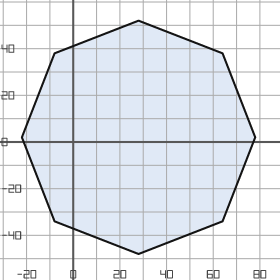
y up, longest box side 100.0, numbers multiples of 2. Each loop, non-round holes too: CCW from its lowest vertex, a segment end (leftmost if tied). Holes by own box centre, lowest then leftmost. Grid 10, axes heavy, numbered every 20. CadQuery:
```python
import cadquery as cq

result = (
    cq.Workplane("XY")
    .moveTo(28.0, -48.0)
    .lineTo(64.0, -34.0)
    .lineTo(78.0, 2.0)
    .lineTo(64.0, 38.0)
    .lineTo(28.0, 52.0)
    .lineTo(-8.0, 38.0)
    .lineTo(-22.0, 2.0)
    .lineTo(-8.0, -34.0)
    .close()
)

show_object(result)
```